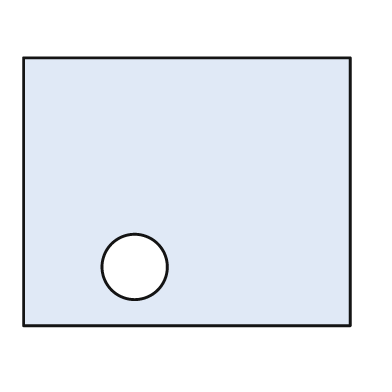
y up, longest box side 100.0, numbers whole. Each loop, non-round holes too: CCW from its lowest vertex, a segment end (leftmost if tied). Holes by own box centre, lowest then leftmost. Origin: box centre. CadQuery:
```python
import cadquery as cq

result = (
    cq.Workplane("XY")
    .moveTo(-50.0, -41.0)
    .lineTo(50.0, -41.0)
    .lineTo(50.0, 41.0)
    .lineTo(-50.0, 41.0)
    .close()
    .moveTo(-16.0, -23.0)
    .circle(10.0)
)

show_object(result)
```